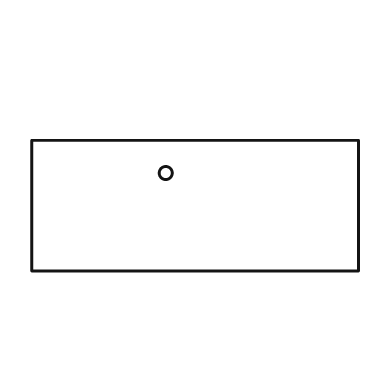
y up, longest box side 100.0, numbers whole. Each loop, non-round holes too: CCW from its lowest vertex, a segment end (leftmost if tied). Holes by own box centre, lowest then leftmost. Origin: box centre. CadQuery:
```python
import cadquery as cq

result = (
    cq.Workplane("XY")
    .moveTo(-50.0, -20.0)
    .lineTo(50.0, -20.0)
    .lineTo(50.0, 20.0)
    .lineTo(-50.0, 20.0)
    .close()
    .moveTo(-9.0, 10.0)
    .circle(2.0)
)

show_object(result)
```